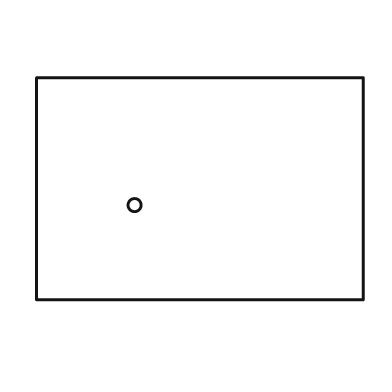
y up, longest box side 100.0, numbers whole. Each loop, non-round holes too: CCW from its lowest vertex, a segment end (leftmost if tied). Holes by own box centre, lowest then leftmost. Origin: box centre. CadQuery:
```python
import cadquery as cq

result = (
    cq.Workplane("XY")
    .moveTo(-50.0, -34.0)
    .lineTo(50.0, -34.0)
    .lineTo(50.0, 34.0)
    .lineTo(-50.0, 34.0)
    .close()
    .moveTo(-20.0, -5.0)
    .circle(2.0)
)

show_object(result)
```